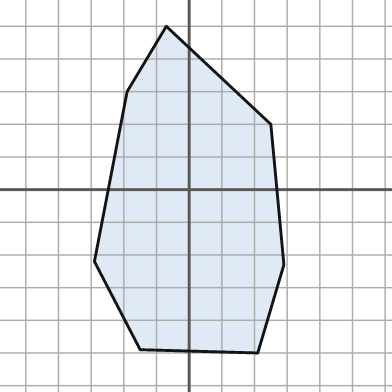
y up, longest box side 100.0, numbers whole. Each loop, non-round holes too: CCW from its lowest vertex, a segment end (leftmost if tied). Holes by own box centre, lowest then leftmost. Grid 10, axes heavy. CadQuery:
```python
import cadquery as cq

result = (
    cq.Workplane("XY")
    .moveTo(21.0, -50.0)
    .lineTo(29.0, -23.0)
    .lineTo(25.0, 20.0)
    .lineTo(-7.0, 50.0)
    .lineTo(-19.0, 30.0)
    .lineTo(-29.0, -22.0)
    .lineTo(-15.0, -49.0)
    .close()
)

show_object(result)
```